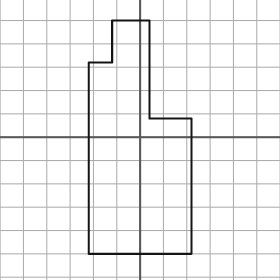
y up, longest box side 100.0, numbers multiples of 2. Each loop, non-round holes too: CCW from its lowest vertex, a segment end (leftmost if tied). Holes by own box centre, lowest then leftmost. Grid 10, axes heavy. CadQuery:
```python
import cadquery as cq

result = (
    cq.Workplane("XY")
    .moveTo(-22.0, -50.0)
    .lineTo(22.0, -50.0)
    .lineTo(22.0, 8.0)
    .lineTo(4.0, 8.0)
    .lineTo(4.0, 50.0)
    .lineTo(-12.0, 50.0)
    .lineTo(-12.0, 32.0)
    .lineTo(-22.0, 32.0)
    .close()
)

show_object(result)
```